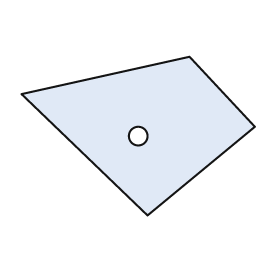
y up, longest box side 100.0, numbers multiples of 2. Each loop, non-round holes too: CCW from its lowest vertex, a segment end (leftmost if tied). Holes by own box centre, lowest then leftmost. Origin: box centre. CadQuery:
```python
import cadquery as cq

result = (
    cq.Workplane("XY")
    .moveTo(4.0, -34.0)
    .lineTo(50.0, 4.0)
    .lineTo(22.0, 34.0)
    .lineTo(-50.0, 18.0)
    .close()
    .moveTo(0.0, 0.0)
    .circle(4.0)
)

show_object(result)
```